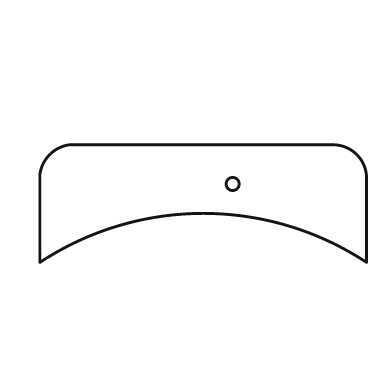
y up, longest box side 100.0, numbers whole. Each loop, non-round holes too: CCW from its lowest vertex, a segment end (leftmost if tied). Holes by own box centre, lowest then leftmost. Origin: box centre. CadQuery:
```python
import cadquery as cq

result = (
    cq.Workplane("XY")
    .moveTo(-50.0, -18.0)
    .threePointArc((0.0, -3.0), (50.0, -18.0))
    .lineTo(50.0, 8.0)
    .threePointArc((47.0, 15.0), (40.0, 18.0))
    .lineTo(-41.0, 18.0)
    .threePointArc((-47.0, 15.0), (-50.0, 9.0))
    .close()
    .moveTo(9.0, 6.0)
    .circle(2.0)
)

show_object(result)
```